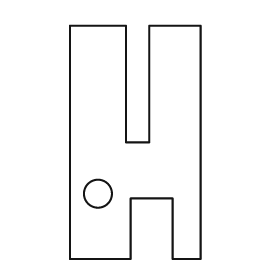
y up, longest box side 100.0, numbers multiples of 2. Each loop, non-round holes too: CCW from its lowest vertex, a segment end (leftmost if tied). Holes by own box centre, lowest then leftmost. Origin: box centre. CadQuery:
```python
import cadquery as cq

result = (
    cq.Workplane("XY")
    .moveTo(-28.0, -50.0)
    .lineTo(-2.0, -50.0)
    .lineTo(-2.0, -24.0)
    .lineTo(16.0, -24.0)
    .lineTo(16.0, -50.0)
    .lineTo(28.0, -50.0)
    .lineTo(28.0, 50.0)
    .lineTo(6.0, 50.0)
    .lineTo(6.0, 0.0)
    .lineTo(-4.0, 0.0)
    .lineTo(-4.0, 50.0)
    .lineTo(-28.0, 50.0)
    .close()
    .moveTo(-16.0, -22.0)
    .circle(6.0)
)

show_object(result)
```